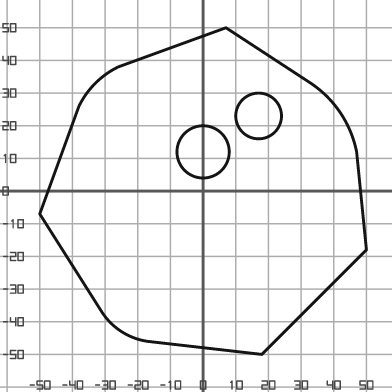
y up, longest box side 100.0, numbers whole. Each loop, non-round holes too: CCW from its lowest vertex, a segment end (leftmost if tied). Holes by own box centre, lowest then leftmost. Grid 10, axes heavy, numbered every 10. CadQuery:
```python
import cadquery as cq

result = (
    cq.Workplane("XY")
    .moveTo(18.0, -50.0)
    .lineTo(50.0, -18.0)
    .lineTo(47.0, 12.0)
    .threePointArc((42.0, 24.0), (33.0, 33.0))
    .lineTo(7.0, 50.0)
    .lineTo(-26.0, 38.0)
    .threePointArc((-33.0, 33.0), (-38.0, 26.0))
    .lineTo(-50.0, -7.0)
    .lineTo(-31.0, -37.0)
    .threePointArc((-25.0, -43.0), (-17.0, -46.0))
    .close()
    .moveTo(0.0, 12.0)
    .circle(8.0)
    .moveTo(17.0, 23.0)
    .circle(7.0)
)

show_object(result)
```